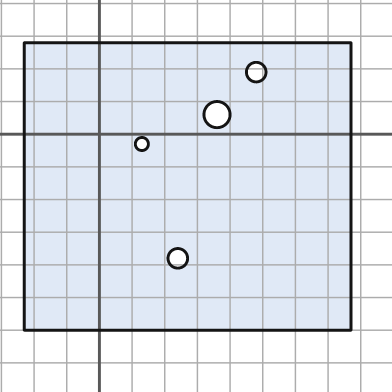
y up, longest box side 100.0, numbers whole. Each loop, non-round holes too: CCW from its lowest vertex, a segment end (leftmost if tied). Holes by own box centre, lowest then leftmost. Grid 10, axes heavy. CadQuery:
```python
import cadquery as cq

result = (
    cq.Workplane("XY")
    .moveTo(-23.0, -60.0)
    .lineTo(77.0, -60.0)
    .lineTo(77.0, 28.0)
    .lineTo(-23.0, 28.0)
    .close()
    .moveTo(24.0, -38.0)
    .circle(3.0)
    .moveTo(13.0, -3.0)
    .circle(2.0)
    .moveTo(36.0, 6.0)
    .circle(4.0)
    .moveTo(48.0, 19.0)
    .circle(3.0)
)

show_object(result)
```